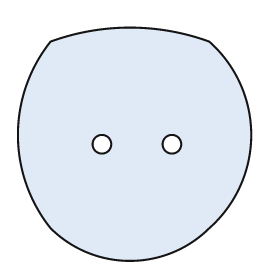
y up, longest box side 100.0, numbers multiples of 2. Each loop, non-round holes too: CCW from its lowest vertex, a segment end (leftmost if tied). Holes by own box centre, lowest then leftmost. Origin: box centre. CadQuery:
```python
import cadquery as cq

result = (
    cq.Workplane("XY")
    .moveTo(-36.0, -36.0)
    .threePointArc((-2.0, -50.0), (32.0, -36.0))
    .threePointArc((50.0, 4.0), (32.0, 44.0))
    .threePointArc((-2.0, 50.0), (-36.0, 44.0))
    .threePointArc((-50.0, 4.0), (-36.0, -36.0))
    .close()
    .moveTo(-14.0, 0.0)
    .circle(4.0)
    .moveTo(16.0, 0.0)
    .circle(4.0)
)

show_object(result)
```